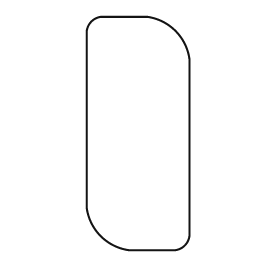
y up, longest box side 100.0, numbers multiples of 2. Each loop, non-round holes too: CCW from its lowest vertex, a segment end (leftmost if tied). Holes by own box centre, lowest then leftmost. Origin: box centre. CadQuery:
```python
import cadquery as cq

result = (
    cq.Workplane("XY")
    .moveTo(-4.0, -50.0)
    .lineTo(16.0, -50.0)
    .threePointArc((20.0, -48.0), (22.0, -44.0))
    .lineTo(22.0, 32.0)
    .threePointArc((16.0, 44.0), (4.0, 50.0))
    .lineTo(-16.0, 50.0)
    .threePointArc((-20.0, 48.0), (-22.0, 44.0))
    .lineTo(-22.0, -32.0)
    .threePointArc((-16.0, -44.0), (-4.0, -50.0))
    .close()
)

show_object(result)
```